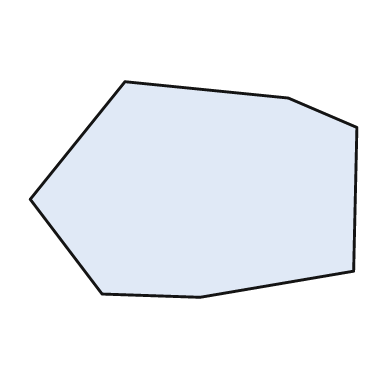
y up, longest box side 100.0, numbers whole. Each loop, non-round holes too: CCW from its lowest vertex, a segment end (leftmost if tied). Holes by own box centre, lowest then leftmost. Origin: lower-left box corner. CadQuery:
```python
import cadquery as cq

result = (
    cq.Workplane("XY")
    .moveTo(52.0, 0.0)
    .lineTo(99.0, 8.0)
    .lineTo(100.0, 52.0)
    .lineTo(79.0, 61.0)
    .lineTo(29.0, 66.0)
    .lineTo(0.0, 30.0)
    .lineTo(22.0, 1.0)
    .close()
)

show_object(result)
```